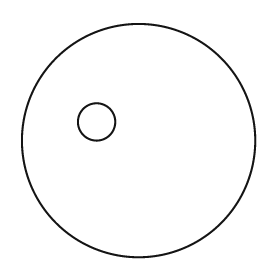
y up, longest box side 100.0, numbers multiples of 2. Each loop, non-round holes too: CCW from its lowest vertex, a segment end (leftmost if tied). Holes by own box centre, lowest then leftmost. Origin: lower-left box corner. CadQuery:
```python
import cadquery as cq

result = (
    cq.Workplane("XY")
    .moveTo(50.0, 50.0)
    .circle(50.0)
    .moveTo(32.0, 58.0)
    .circle(8.0)
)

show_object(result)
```